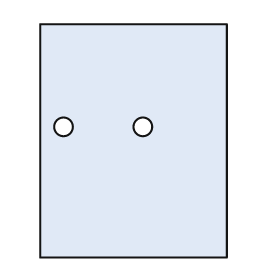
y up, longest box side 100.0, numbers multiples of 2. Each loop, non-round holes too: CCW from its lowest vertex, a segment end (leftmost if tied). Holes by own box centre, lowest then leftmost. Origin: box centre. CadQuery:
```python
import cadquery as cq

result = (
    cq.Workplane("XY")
    .moveTo(-40.0, -50.0)
    .lineTo(40.0, -50.0)
    .lineTo(40.0, 50.0)
    .lineTo(-40.0, 50.0)
    .close()
    .moveTo(-30.0, 6.0)
    .circle(4.0)
    .moveTo(4.0, 6.0)
    .circle(4.0)
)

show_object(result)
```